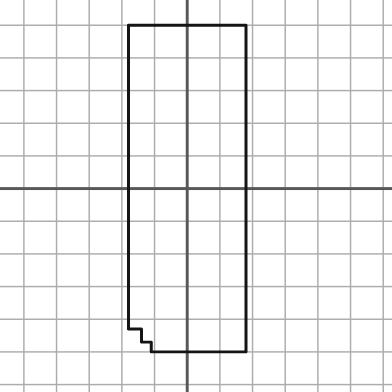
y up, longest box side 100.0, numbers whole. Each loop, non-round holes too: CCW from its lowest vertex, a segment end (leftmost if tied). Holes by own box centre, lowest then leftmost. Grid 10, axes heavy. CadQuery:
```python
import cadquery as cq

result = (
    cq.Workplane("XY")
    .moveTo(-11.0, -50.0)
    .lineTo(18.0, -50.0)
    .lineTo(18.0, 50.0)
    .lineTo(-18.0, 50.0)
    .lineTo(-18.0, -43.0)
    .lineTo(-14.0, -43.0)
    .lineTo(-14.0, -47.0)
    .lineTo(-11.0, -47.0)
    .close()
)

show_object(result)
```